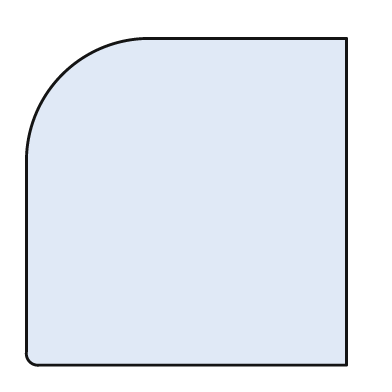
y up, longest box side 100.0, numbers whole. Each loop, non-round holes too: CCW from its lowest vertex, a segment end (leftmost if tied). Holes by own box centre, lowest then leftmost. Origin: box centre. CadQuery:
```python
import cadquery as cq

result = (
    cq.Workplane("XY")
    .moveTo(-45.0, -50.0)
    .lineTo(49.0, -50.0)
    .lineTo(49.0, 50.0)
    .lineTo(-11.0, 50.0)
    .threePointArc((-38.0, 39.0), (-49.0, 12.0))
    .lineTo(-49.0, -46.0)
    .threePointArc((-48.0, -49.0), (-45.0, -50.0))
    .close()
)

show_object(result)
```